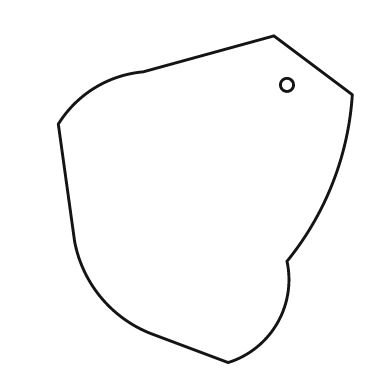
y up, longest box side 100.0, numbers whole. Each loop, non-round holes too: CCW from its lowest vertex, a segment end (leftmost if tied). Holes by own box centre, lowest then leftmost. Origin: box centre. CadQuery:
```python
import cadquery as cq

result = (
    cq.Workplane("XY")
    .moveTo(7.0, -50.0)
    .threePointArc((22.0, -38.0), (25.0, -19.0))
    .threePointArc((39.0, 5.0), (45.0, 32.0))
    .lineTo(21.0, 50.0)
    .lineTo(-19.0, 39.0)
    .threePointArc((-34.0, 34.0), (-45.0, 23.0))
    .lineTo(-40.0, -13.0)
    .threePointArc((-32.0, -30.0), (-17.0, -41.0))
    .close()
    .moveTo(25.0, 35.0)
    .circle(2.0)
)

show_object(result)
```